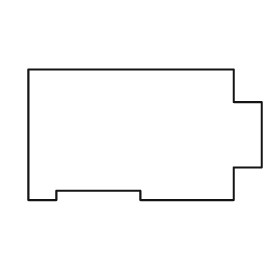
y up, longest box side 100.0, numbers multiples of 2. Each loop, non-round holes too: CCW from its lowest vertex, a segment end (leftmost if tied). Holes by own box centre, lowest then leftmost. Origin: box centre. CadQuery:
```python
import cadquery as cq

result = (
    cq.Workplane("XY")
    .moveTo(-50.0, -28.0)
    .lineTo(-38.0, -28.0)
    .lineTo(-38.0, -24.0)
    .lineTo(-2.0, -24.0)
    .lineTo(-2.0, -28.0)
    .lineTo(38.0, -28.0)
    .lineTo(38.0, -14.0)
    .lineTo(50.0, -14.0)
    .lineTo(50.0, 14.0)
    .lineTo(38.0, 14.0)
    .lineTo(38.0, 28.0)
    .lineTo(-50.0, 28.0)
    .close()
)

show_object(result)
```